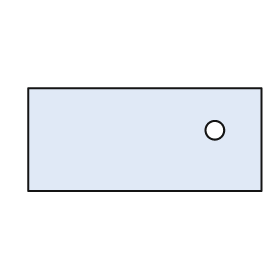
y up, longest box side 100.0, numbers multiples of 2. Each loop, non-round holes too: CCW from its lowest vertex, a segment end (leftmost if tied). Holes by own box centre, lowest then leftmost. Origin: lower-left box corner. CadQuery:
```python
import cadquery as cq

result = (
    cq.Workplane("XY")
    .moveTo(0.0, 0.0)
    .lineTo(100.0, 0.0)
    .lineTo(100.0, 44.0)
    .lineTo(0.0, 44.0)
    .close()
    .moveTo(80.0, 26.0)
    .circle(4.0)
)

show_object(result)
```